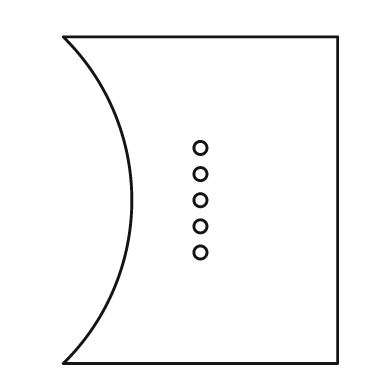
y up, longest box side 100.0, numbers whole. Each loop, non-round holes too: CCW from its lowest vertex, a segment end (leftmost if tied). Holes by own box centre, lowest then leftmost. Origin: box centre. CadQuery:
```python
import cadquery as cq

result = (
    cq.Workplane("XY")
    .moveTo(-42.0, -50.0)
    .lineTo(42.0, -50.0)
    .lineTo(42.0, 50.0)
    .lineTo(-42.0, 50.0)
    .threePointArc((-21.0, 0.0), (-42.0, -50.0))
    .close()
    .moveTo(0.0, -16.0)
    .circle(2.0)
    .moveTo(0.0, -8.0)
    .circle(2.0)
    .moveTo(0.0, 0.0)
    .circle(2.0)
    .moveTo(0.0, 8.0)
    .circle(2.0)
    .moveTo(0.0, 16.0)
    .circle(2.0)
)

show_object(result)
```